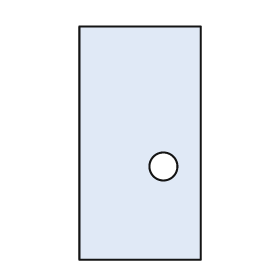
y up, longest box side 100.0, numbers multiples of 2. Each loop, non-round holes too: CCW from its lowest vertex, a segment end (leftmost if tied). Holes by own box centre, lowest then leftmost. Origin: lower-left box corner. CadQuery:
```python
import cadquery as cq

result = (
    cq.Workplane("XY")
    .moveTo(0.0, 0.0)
    .lineTo(52.0, 0.0)
    .lineTo(52.0, 100.0)
    .lineTo(0.0, 100.0)
    .close()
    .moveTo(36.0, 40.0)
    .circle(6.0)
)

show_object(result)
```